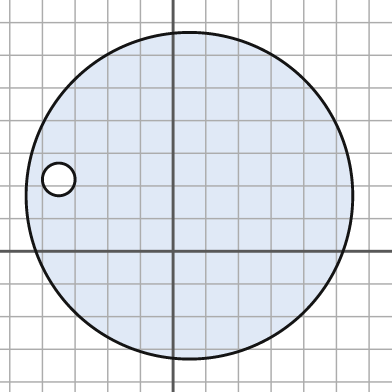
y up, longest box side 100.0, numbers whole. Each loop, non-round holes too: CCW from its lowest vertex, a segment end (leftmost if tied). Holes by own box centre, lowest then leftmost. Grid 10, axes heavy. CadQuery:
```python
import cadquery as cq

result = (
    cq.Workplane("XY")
    .moveTo(5.0, 17.0)
    .circle(50.0)
    .moveTo(-35.0, 22.0)
    .circle(5.0)
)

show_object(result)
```